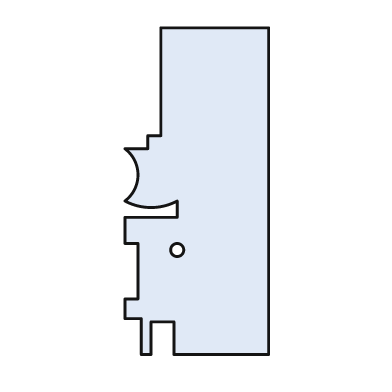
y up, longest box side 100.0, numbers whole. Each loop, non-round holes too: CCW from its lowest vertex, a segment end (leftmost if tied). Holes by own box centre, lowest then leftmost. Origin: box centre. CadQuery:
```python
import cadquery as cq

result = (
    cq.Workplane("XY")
    .moveTo(-17.0, -50.0)
    .lineTo(-14.0, -50.0)
    .lineTo(-14.0, -40.0)
    .lineTo(-7.0, -40.0)
    .lineTo(-7.0, -50.0)
    .lineTo(22.0, -50.0)
    .lineTo(22.0, 50.0)
    .lineTo(-11.0, 50.0)
    .lineTo(-11.0, 17.0)
    .lineTo(-15.0, 17.0)
    .lineTo(-15.0, 13.0)
    .lineTo(-22.0, 13.0)
    .threePointArc((-18.0, 5.0), (-22.0, -3.0))
    .threePointArc((-14.0, -5.0), (-6.0, -3.0))
    .lineTo(-6.0, -8.0)
    .lineTo(-22.0, -8.0)
    .lineTo(-22.0, -16.0)
    .lineTo(-18.0, -16.0)
    .lineTo(-18.0, -33.0)
    .lineTo(-22.0, -33.0)
    .lineTo(-22.0, -39.0)
    .lineTo(-17.0, -39.0)
    .close()
    .moveTo(-6.0, -18.0)
    .circle(2.0)
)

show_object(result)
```